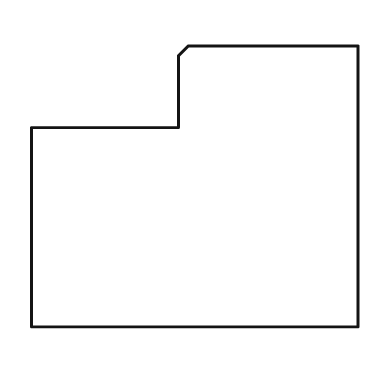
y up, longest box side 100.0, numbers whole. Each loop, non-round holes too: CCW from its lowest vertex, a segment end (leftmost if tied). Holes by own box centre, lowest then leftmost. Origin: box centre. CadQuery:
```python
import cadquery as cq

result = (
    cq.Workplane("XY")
    .moveTo(-50.0, -43.0)
    .lineTo(50.0, -43.0)
    .lineTo(50.0, 43.0)
    .lineTo(-2.0, 43.0)
    .lineTo(-5.0, 40.0)
    .lineTo(-5.0, 18.0)
    .lineTo(-50.0, 18.0)
    .close()
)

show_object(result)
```